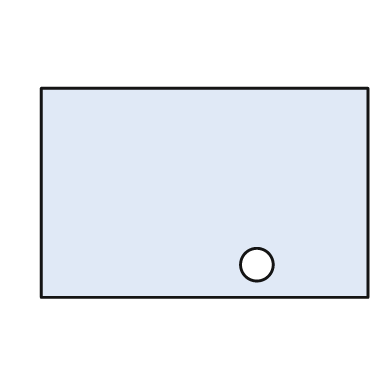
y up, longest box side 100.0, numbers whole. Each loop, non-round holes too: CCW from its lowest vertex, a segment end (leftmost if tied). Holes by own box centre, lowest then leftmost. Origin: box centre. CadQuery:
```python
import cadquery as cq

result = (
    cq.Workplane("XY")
    .moveTo(-50.0, -32.0)
    .lineTo(50.0, -32.0)
    .lineTo(50.0, 32.0)
    .lineTo(-50.0, 32.0)
    .close()
    .moveTo(16.0, -22.0)
    .circle(5.0)
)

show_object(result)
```